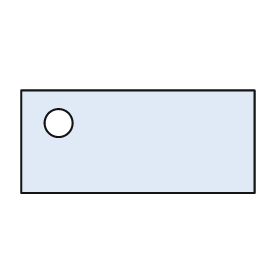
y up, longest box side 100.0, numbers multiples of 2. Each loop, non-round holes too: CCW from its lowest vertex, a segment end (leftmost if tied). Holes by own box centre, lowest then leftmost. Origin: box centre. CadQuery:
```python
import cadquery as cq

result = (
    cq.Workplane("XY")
    .moveTo(-50.0, -22.0)
    .lineTo(50.0, -22.0)
    .lineTo(50.0, 22.0)
    .lineTo(-50.0, 22.0)
    .close()
    .moveTo(-34.0, 8.0)
    .circle(6.0)
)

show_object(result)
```